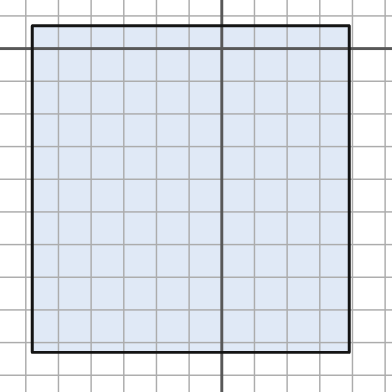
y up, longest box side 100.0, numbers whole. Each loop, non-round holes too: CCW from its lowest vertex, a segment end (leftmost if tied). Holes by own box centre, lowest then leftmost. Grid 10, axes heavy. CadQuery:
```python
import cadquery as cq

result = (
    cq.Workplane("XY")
    .moveTo(-58.0, -93.0)
    .lineTo(39.0, -93.0)
    .lineTo(39.0, 7.0)
    .lineTo(-58.0, 7.0)
    .close()
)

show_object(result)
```